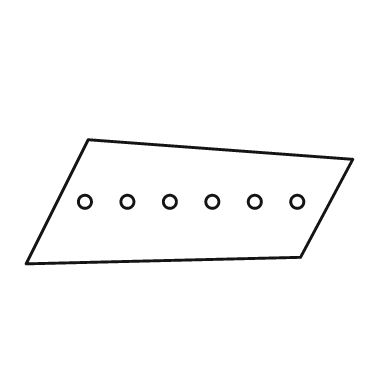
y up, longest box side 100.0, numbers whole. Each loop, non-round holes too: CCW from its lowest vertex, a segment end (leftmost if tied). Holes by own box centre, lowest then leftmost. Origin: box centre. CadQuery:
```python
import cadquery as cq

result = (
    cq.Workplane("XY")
    .moveTo(-50.0, -19.0)
    .lineTo(34.0, -17.0)
    .lineTo(50.0, 13.0)
    .lineTo(-31.0, 19.0)
    .close()
    .moveTo(-32.0, 0.0)
    .circle(2.0)
    .moveTo(-19.0, 0.0)
    .circle(2.0)
    .moveTo(-6.0, 0.0)
    .circle(2.0)
    .moveTo(7.0, 0.0)
    .circle(2.0)
    .moveTo(20.0, 0.0)
    .circle(2.0)
    .moveTo(33.0, 0.0)
    .circle(2.0)
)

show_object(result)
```